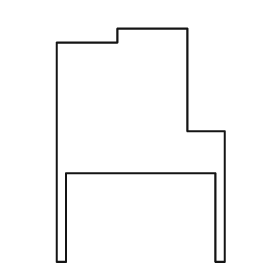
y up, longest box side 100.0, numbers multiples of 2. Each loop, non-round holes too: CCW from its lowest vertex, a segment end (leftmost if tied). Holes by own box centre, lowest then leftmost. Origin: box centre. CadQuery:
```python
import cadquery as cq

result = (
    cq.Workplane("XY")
    .moveTo(-36.0, -50.0)
    .lineTo(-32.0, -50.0)
    .lineTo(-32.0, -12.0)
    .lineTo(32.0, -12.0)
    .lineTo(32.0, -50.0)
    .lineTo(36.0, -50.0)
    .lineTo(36.0, 6.0)
    .lineTo(20.0, 6.0)
    .lineTo(20.0, 50.0)
    .lineTo(-10.0, 50.0)
    .lineTo(-10.0, 44.0)
    .lineTo(-36.0, 44.0)
    .close()
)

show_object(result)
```